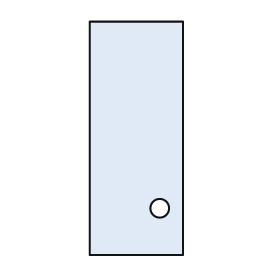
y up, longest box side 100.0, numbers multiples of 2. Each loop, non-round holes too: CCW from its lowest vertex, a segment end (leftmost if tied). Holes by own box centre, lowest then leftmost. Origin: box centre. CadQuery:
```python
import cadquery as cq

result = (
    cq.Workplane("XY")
    .moveTo(-20.0, -50.0)
    .lineTo(20.0, -50.0)
    .lineTo(20.0, 50.0)
    .lineTo(-20.0, 50.0)
    .close()
    .moveTo(10.0, -30.0)
    .circle(4.0)
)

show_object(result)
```